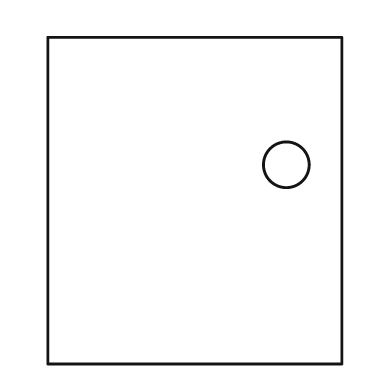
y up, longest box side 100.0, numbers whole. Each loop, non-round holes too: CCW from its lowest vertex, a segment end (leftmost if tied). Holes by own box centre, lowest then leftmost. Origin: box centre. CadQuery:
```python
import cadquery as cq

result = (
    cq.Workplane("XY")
    .moveTo(-45.0, -50.0)
    .lineTo(45.0, -50.0)
    .lineTo(45.0, 50.0)
    .lineTo(-45.0, 50.0)
    .close()
    .moveTo(28.0, 11.0)
    .circle(7.0)
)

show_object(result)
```